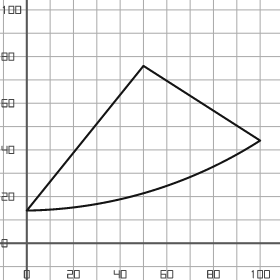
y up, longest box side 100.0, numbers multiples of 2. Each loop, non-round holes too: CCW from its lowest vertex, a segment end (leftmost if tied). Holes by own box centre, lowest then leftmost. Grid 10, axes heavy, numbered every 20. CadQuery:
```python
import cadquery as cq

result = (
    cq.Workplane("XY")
    .moveTo(0.0, 14.0)
    .threePointArc((52.0, 22.0), (100.0, 44.0))
    .lineTo(50.0, 76.0)
    .close()
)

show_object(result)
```